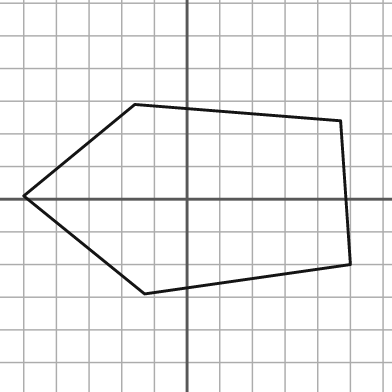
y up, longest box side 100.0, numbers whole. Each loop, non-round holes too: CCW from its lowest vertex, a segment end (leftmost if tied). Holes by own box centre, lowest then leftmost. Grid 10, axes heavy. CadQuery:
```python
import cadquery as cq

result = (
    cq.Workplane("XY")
    .moveTo(-13.0, -29.0)
    .lineTo(50.0, -20.0)
    .lineTo(47.0, 24.0)
    .lineTo(-16.0, 29.0)
    .lineTo(-50.0, 1.0)
    .close()
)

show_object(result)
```